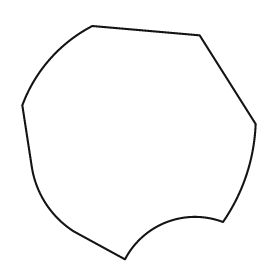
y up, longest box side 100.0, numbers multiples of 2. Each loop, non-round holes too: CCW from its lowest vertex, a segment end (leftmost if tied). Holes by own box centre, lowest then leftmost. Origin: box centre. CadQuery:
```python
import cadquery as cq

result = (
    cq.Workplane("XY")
    .moveTo(-6.0, -50.0)
    .threePointArc((12.0, -34.0), (36.0, -34.0))
    .threePointArc((46.0, -14.0), (50.0, 8.0))
    .lineTo(26.0, 46.0)
    .lineTo(-20.0, 50.0)
    .threePointArc((-38.0, 36.0), (-50.0, 16.0))
    .lineTo(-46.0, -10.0)
    .threePointArc((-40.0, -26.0), (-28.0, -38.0))
    .close()
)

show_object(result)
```